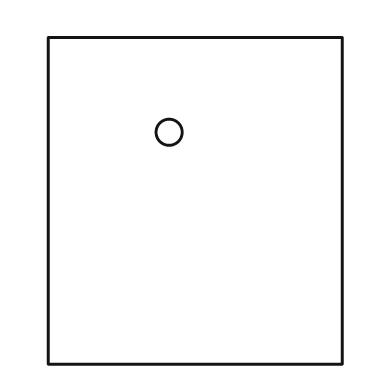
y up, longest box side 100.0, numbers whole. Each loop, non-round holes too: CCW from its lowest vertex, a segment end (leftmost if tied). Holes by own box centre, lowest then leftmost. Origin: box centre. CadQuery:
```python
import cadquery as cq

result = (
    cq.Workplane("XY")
    .moveTo(-45.0, -50.0)
    .lineTo(45.0, -50.0)
    .lineTo(45.0, 50.0)
    .lineTo(-45.0, 50.0)
    .close()
    .moveTo(-8.0, 21.0)
    .circle(4.0)
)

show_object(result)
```